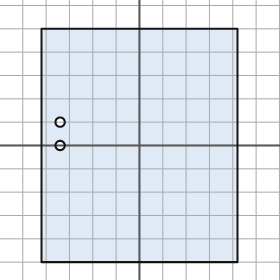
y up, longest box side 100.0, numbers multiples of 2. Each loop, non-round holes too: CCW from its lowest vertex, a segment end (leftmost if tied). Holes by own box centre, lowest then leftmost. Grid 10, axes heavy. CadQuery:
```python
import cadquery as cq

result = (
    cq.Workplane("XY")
    .moveTo(-42.0, -50.0)
    .lineTo(42.0, -50.0)
    .lineTo(42.0, 50.0)
    .lineTo(-42.0, 50.0)
    .close()
    .moveTo(-34.0, 0.0)
    .circle(2.0)
    .moveTo(-34.0, 10.0)
    .circle(2.0)
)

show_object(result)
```